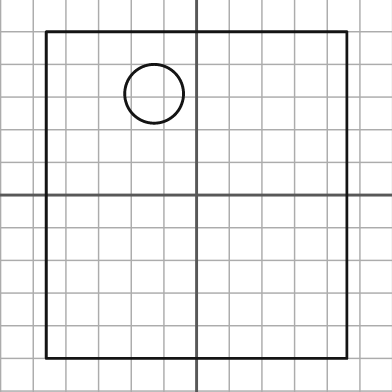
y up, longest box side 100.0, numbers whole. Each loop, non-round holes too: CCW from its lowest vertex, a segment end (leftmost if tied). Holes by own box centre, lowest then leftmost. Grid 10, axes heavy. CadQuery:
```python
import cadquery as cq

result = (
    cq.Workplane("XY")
    .moveTo(-46.0, -50.0)
    .lineTo(46.0, -50.0)
    .lineTo(46.0, 50.0)
    .lineTo(-46.0, 50.0)
    .close()
    .moveTo(-13.0, 31.0)
    .circle(9.0)
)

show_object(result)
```